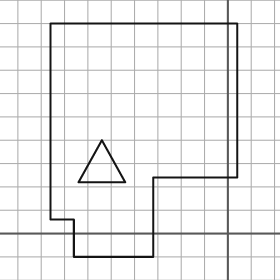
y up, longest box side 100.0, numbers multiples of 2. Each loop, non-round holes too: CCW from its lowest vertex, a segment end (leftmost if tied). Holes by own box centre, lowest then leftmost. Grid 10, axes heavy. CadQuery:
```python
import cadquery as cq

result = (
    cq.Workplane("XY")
    .moveTo(-66.0, -10.0)
    .lineTo(-32.0, -10.0)
    .lineTo(-32.0, 24.0)
    .lineTo(4.0, 24.0)
    .lineTo(4.0, 90.0)
    .lineTo(-76.0, 90.0)
    .lineTo(-76.0, 6.0)
    .lineTo(-66.0, 6.0)
    .close()
    .moveTo(-64.0, 22.0)
    .lineTo(-44.0, 22.0)
    .lineTo(-54.0, 40.0)
    .close()
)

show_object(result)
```